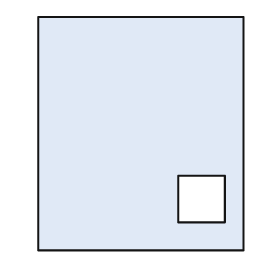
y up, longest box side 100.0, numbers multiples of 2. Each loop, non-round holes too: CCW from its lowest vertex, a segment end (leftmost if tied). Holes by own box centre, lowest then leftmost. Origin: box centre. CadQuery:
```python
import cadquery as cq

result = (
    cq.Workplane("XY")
    .moveTo(-44.0, -50.0)
    .lineTo(44.0, -50.0)
    .lineTo(44.0, 50.0)
    .lineTo(-44.0, 50.0)
    .close()
    .moveTo(16.0, -38.0)
    .lineTo(36.0, -38.0)
    .lineTo(36.0, -18.0)
    .lineTo(16.0, -18.0)
    .close()
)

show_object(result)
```